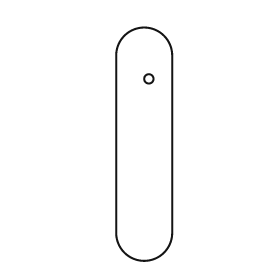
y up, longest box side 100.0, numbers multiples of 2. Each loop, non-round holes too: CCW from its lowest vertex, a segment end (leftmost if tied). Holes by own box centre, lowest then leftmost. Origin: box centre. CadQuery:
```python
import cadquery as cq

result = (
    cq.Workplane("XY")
    .moveTo(-12.0, -38.0)
    .threePointArc((0.0, -50.0), (12.0, -38.0))
    .lineTo(12.0, 38.0)
    .threePointArc((0.0, 50.0), (-12.0, 38.0))
    .close()
    .moveTo(2.0, 28.0)
    .circle(2.0)
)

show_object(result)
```